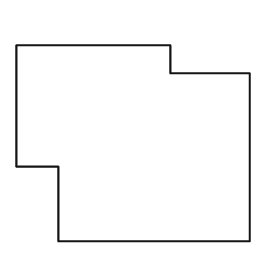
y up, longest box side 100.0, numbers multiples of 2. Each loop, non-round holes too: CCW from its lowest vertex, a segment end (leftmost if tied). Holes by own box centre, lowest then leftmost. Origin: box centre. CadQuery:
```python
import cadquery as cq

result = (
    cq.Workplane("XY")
    .moveTo(-32.0, -42.0)
    .lineTo(50.0, -42.0)
    .lineTo(50.0, 30.0)
    .lineTo(16.0, 30.0)
    .lineTo(16.0, 42.0)
    .lineTo(-50.0, 42.0)
    .lineTo(-50.0, -10.0)
    .lineTo(-32.0, -10.0)
    .close()
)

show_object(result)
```